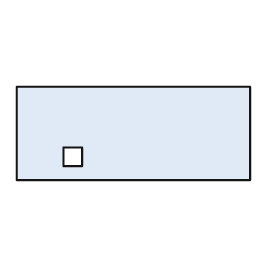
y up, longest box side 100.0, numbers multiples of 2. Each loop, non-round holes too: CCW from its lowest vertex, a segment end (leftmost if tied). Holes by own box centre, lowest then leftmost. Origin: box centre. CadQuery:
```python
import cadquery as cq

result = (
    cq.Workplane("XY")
    .moveTo(-50.0, -20.0)
    .lineTo(50.0, -20.0)
    .lineTo(50.0, 20.0)
    .lineTo(-50.0, 20.0)
    .close()
    .moveTo(-30.0, -14.0)
    .lineTo(-22.0, -14.0)
    .lineTo(-22.0, -6.0)
    .lineTo(-30.0, -6.0)
    .close()
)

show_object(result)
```